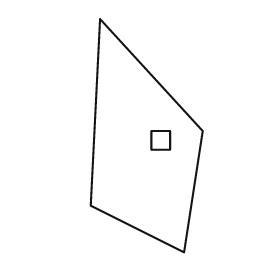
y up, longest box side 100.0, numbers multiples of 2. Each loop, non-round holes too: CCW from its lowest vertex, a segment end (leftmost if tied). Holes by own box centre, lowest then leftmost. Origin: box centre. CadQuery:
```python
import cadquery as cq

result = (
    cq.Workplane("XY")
    .moveTo(16.0, -50.0)
    .lineTo(24.0, 2.0)
    .lineTo(-20.0, 50.0)
    .lineTo(-24.0, -30.0)
    .close()
    .moveTo(2.0, -6.0)
    .lineTo(10.0, -6.0)
    .lineTo(10.0, 2.0)
    .lineTo(2.0, 2.0)
    .close()
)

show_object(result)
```